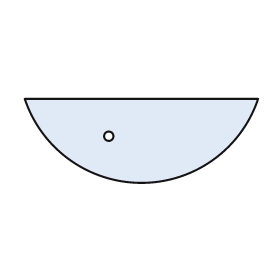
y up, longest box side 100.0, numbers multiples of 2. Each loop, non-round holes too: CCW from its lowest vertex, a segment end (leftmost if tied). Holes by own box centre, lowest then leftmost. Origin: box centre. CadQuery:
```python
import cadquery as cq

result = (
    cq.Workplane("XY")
    .moveTo(-50.0, 18.0)
    .threePointArc((0.0, -18.0), (50.0, 18.0))
    .close()
    .moveTo(-14.0, 2.0)
    .circle(2.0)
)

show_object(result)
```